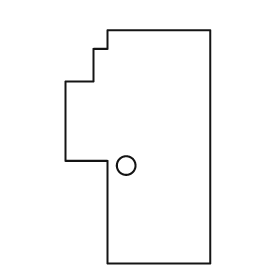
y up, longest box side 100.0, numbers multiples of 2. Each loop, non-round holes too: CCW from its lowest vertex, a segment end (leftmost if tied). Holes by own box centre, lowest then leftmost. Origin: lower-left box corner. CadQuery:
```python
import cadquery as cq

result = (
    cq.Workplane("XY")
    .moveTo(18.0, 0.0)
    .lineTo(62.0, 0.0)
    .lineTo(62.0, 100.0)
    .lineTo(18.0, 100.0)
    .lineTo(18.0, 92.0)
    .lineTo(12.0, 92.0)
    .lineTo(12.0, 78.0)
    .lineTo(0.0, 78.0)
    .lineTo(0.0, 44.0)
    .lineTo(18.0, 44.0)
    .close()
    .moveTo(26.0, 42.0)
    .circle(4.0)
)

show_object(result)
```